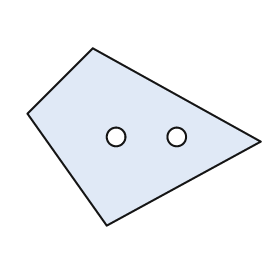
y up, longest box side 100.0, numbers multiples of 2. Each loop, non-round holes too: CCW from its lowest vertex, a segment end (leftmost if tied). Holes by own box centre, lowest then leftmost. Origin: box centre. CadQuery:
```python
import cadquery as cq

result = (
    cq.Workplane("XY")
    .moveTo(-16.0, -38.0)
    .lineTo(50.0, -2.0)
    .lineTo(-22.0, 38.0)
    .lineTo(-50.0, 10.0)
    .close()
    .moveTo(-12.0, 0.0)
    .circle(4.0)
    .moveTo(14.0, 0.0)
    .circle(4.0)
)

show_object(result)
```